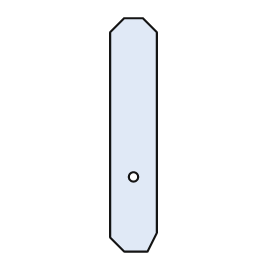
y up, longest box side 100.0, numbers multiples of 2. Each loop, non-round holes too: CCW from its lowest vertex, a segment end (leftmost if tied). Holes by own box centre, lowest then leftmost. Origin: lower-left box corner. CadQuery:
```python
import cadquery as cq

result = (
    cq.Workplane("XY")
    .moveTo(6.0, 0.0)
    .lineTo(16.0, 0.0)
    .lineTo(20.0, 8.0)
    .lineTo(20.0, 94.0)
    .lineTo(14.0, 100.0)
    .lineTo(6.0, 100.0)
    .lineTo(0.0, 94.0)
    .lineTo(0.0, 6.0)
    .close()
    .moveTo(10.0, 32.0)
    .circle(2.0)
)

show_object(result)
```